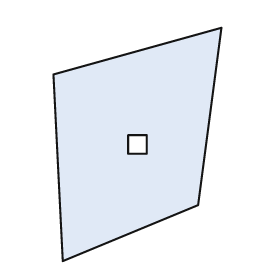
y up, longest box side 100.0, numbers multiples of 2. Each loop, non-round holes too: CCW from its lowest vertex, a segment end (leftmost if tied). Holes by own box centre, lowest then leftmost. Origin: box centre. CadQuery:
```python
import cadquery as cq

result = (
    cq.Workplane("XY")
    .moveTo(-32.0, -50.0)
    .lineTo(26.0, -26.0)
    .lineTo(36.0, 50.0)
    .lineTo(-36.0, 30.0)
    .close()
    .moveTo(-4.0, -4.0)
    .lineTo(4.0, -4.0)
    .lineTo(4.0, 4.0)
    .lineTo(-4.0, 4.0)
    .close()
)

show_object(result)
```